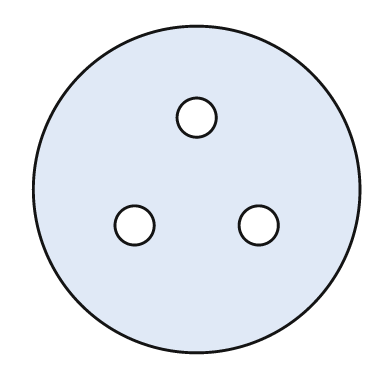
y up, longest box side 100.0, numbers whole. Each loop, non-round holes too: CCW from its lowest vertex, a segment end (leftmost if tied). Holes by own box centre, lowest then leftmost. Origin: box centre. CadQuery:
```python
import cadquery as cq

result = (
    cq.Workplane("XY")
    .moveTo(0.0, 0.0)
    .circle(50.0)
    .moveTo(-19.0, -11.0)
    .circle(6.0)
    .moveTo(19.0, -11.0)
    .circle(6.0)
    .moveTo(0.0, 22.0)
    .circle(6.0)
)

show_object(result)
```